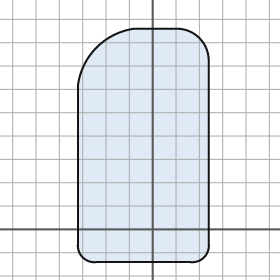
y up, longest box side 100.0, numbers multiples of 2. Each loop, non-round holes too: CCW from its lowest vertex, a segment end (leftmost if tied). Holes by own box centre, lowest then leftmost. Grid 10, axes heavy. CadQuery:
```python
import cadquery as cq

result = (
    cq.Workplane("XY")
    .moveTo(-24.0, -14.0)
    .lineTo(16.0, -14.0)
    .threePointArc((22.0, -12.0), (24.0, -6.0))
    .lineTo(24.0, 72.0)
    .threePointArc((20.0, 82.0), (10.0, 86.0))
    .lineTo(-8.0, 86.0)
    .threePointArc((-24.0, 78.0), (-32.0, 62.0))
    .lineTo(-32.0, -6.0)
    .threePointArc((-30.0, -12.0), (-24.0, -14.0))
    .close()
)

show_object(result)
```